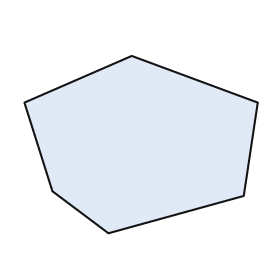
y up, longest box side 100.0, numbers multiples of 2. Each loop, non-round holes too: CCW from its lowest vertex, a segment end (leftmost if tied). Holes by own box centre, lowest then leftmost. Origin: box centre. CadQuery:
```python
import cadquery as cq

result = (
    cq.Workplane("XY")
    .moveTo(-14.0, -38.0)
    .lineTo(44.0, -22.0)
    .lineTo(50.0, 18.0)
    .lineTo(-4.0, 38.0)
    .lineTo(-50.0, 18.0)
    .lineTo(-38.0, -20.0)
    .close()
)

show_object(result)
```